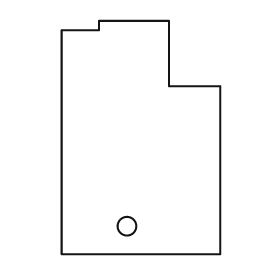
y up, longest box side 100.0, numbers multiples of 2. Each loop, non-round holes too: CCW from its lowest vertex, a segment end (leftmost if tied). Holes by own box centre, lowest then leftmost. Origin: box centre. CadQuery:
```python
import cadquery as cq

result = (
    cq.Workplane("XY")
    .moveTo(-34.0, -50.0)
    .lineTo(34.0, -50.0)
    .lineTo(34.0, 22.0)
    .lineTo(12.0, 22.0)
    .lineTo(12.0, 50.0)
    .lineTo(-18.0, 50.0)
    .lineTo(-18.0, 46.0)
    .lineTo(-34.0, 46.0)
    .close()
    .moveTo(-6.0, -38.0)
    .circle(4.0)
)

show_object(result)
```